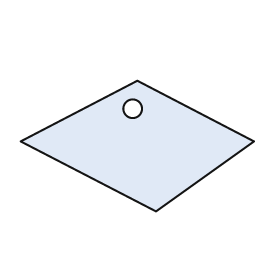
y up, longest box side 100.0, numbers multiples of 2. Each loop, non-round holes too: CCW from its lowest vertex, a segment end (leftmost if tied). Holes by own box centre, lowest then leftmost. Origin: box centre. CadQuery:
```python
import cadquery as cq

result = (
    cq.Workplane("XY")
    .moveTo(8.0, -28.0)
    .lineTo(50.0, 2.0)
    .lineTo(0.0, 28.0)
    .lineTo(-50.0, 2.0)
    .close()
    .moveTo(-2.0, 16.0)
    .circle(4.0)
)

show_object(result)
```